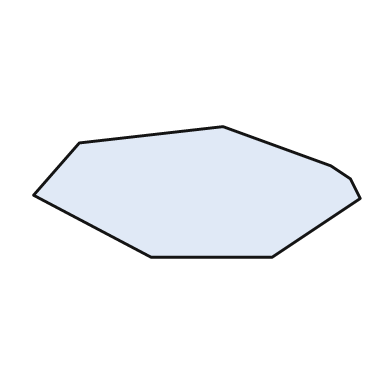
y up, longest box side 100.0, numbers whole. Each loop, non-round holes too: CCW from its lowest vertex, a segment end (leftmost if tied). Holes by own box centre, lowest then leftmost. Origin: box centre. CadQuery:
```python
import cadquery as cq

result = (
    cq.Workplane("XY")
    .moveTo(-14.0, -20.0)
    .lineTo(23.0, -20.0)
    .lineTo(50.0, -2.0)
    .lineTo(47.0, 4.0)
    .lineTo(41.0, 8.0)
    .lineTo(8.0, 20.0)
    .lineTo(-36.0, 15.0)
    .lineTo(-50.0, -1.0)
    .close()
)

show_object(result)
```